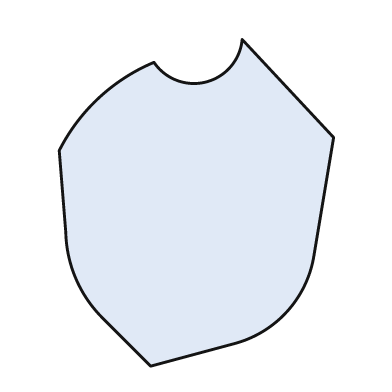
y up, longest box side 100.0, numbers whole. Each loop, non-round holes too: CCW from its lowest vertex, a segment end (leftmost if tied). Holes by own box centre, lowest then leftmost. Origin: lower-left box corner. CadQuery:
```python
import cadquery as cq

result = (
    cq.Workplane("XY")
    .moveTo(28.0, 0.0)
    .lineTo(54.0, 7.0)
    .threePointArc((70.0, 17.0), (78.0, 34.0))
    .lineTo(84.0, 70.0)
    .lineTo(56.0, 100.0)
    .threePointArc((45.0, 87.0), (29.0, 93.0))
    .threePointArc((12.0, 82.0), (0.0, 66.0))
    .lineTo(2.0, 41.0)
    .threePointArc((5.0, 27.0), (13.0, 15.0))
    .close()
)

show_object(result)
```